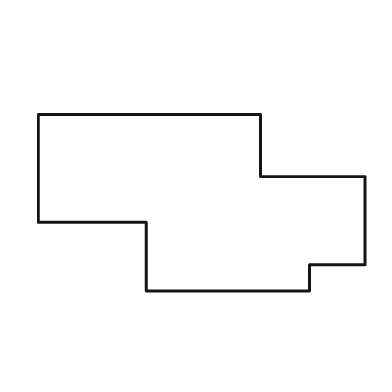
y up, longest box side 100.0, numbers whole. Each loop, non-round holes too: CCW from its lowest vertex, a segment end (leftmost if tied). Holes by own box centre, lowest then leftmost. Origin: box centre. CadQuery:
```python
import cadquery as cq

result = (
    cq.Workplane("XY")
    .moveTo(-17.0, -27.0)
    .lineTo(33.0, -27.0)
    .lineTo(33.0, -19.0)
    .lineTo(50.0, -19.0)
    .lineTo(50.0, 8.0)
    .lineTo(18.0, 8.0)
    .lineTo(18.0, 27.0)
    .lineTo(-50.0, 27.0)
    .lineTo(-50.0, -6.0)
    .lineTo(-17.0, -6.0)
    .close()
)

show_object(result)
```